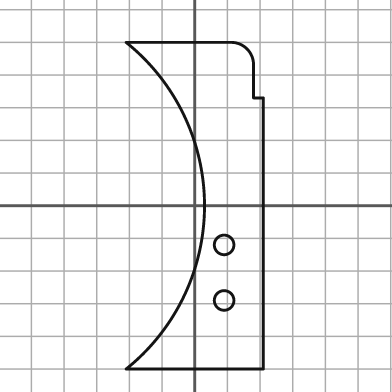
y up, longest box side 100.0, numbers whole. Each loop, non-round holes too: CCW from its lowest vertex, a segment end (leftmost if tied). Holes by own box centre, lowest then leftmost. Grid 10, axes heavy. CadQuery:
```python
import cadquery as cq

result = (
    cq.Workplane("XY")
    .moveTo(-21.0, -50.0)
    .lineTo(21.0, -50.0)
    .lineTo(21.0, 33.0)
    .lineTo(18.0, 33.0)
    .lineTo(18.0, 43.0)
    .threePointArc((16.0, 48.0), (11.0, 50.0))
    .lineTo(-21.0, 50.0)
    .threePointArc((3.0, 0.0), (-21.0, -50.0))
    .close()
    .moveTo(9.0, -29.0)
    .circle(3.0)
    .moveTo(9.0, -12.0)
    .circle(3.0)
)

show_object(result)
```